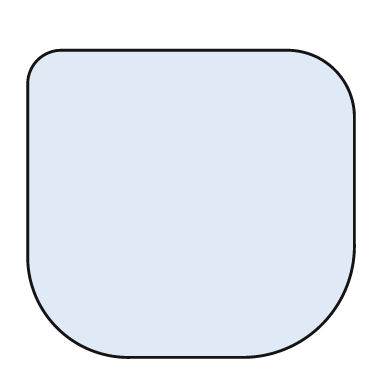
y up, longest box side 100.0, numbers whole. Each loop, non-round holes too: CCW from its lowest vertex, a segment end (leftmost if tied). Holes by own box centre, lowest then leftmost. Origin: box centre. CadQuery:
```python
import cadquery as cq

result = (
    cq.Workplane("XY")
    .moveTo(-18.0, -47.0)
    .lineTo(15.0, -47.0)
    .threePointArc((40.0, -37.0), (50.0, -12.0))
    .lineTo(50.0, 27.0)
    .threePointArc((44.0, 41.0), (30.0, 47.0))
    .lineTo(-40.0, 47.0)
    .threePointArc((-47.0, 44.0), (-50.0, 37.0))
    .lineTo(-50.0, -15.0)
    .threePointArc((-41.0, -38.0), (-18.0, -47.0))
    .close()
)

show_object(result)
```